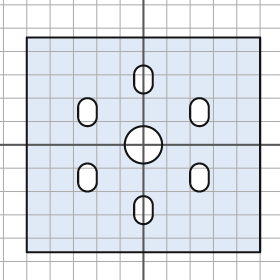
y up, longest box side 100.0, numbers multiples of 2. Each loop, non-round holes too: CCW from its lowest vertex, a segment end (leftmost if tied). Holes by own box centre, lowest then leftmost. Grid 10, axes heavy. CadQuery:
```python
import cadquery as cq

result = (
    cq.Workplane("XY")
    .moveTo(-50.0, -46.0)
    .lineTo(50.0, -46.0)
    .lineTo(50.0, 46.0)
    .lineTo(-50.0, 46.0)
    .close()
    .moveTo(-4.0, -30.0)
    .threePointArc((0.0, -34.0), (4.0, -30.0))
    .lineTo(4.0, -26.0)
    .threePointArc((0.0, -22.0), (-4.0, -26.0))
    .close()
    .moveTo(-28.0, -16.0)
    .threePointArc((-24.0, -20.0), (-20.0, -16.0))
    .lineTo(-20.0, -12.0)
    .threePointArc((-24.0, -8.0), (-28.0, -12.0))
    .close()
    .moveTo(20.0, -16.0)
    .threePointArc((24.0, -20.0), (28.0, -16.0))
    .lineTo(28.0, -12.0)
    .threePointArc((24.0, -8.0), (20.0, -12.0))
    .close()
    .moveTo(0.0, 0.0)
    .circle(8.0)
    .moveTo(-28.0, 12.0)
    .threePointArc((-24.0, 8.0), (-20.0, 12.0))
    .lineTo(-20.0, 16.0)
    .threePointArc((-24.0, 20.0), (-28.0, 16.0))
    .close()
    .moveTo(20.0, 12.0)
    .threePointArc((24.0, 8.0), (28.0, 12.0))
    .lineTo(28.0, 16.0)
    .threePointArc((24.0, 20.0), (20.0, 16.0))
    .close()
    .moveTo(-4.0, 26.0)
    .threePointArc((0.0, 22.0), (4.0, 26.0))
    .lineTo(4.0, 30.0)
    .threePointArc((0.0, 34.0), (-4.0, 30.0))
    .close()
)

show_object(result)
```